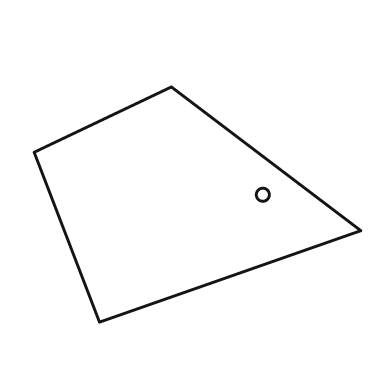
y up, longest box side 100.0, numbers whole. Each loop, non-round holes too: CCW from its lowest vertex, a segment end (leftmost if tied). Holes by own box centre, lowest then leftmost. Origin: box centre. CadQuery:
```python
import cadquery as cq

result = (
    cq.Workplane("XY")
    .moveTo(-30.0, -36.0)
    .lineTo(50.0, -8.0)
    .lineTo(-8.0, 36.0)
    .lineTo(-50.0, 16.0)
    .close()
    .moveTo(20.0, 3.0)
    .circle(2.0)
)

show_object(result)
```